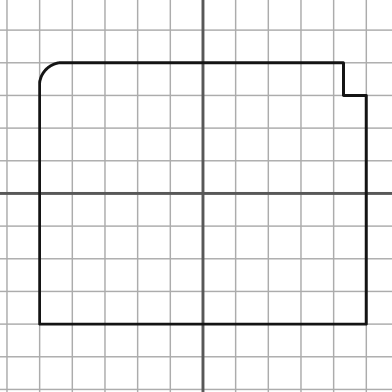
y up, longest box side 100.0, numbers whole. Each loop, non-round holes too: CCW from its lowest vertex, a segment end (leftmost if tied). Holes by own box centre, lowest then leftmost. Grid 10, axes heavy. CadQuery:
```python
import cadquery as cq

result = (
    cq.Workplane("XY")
    .moveTo(-50.0, -40.0)
    .lineTo(50.0, -40.0)
    .lineTo(50.0, 30.0)
    .lineTo(43.0, 30.0)
    .lineTo(43.0, 40.0)
    .lineTo(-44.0, 40.0)
    .threePointArc((-48.0, 38.0), (-50.0, 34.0))
    .close()
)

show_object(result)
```